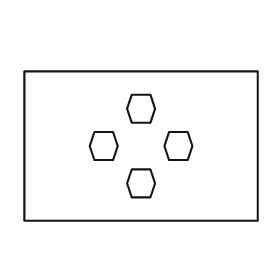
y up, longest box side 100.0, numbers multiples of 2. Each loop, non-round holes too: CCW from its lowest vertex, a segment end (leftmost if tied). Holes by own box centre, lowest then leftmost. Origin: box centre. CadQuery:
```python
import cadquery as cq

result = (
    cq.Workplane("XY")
    .moveTo(-50.0, -32.0)
    .lineTo(50.0, -32.0)
    .lineTo(50.0, 32.0)
    .lineTo(-50.0, 32.0)
    .close()
    .moveTo(-4.0, -22.0)
    .lineTo(4.0, -22.0)
    .lineTo(6.0, -16.0)
    .lineTo(4.0, -10.0)
    .lineTo(-4.0, -10.0)
    .lineTo(-6.0, -16.0)
    .close()
    .moveTo(-20.0, -6.0)
    .lineTo(-12.0, -6.0)
    .lineTo(-10.0, 0.0)
    .lineTo(-12.0, 6.0)
    .lineTo(-20.0, 6.0)
    .lineTo(-22.0, 0.0)
    .close()
    .moveTo(12.0, -6.0)
    .lineTo(20.0, -6.0)
    .lineTo(22.0, 0.0)
    .lineTo(20.0, 6.0)
    .lineTo(12.0, 6.0)
    .lineTo(10.0, 0.0)
    .close()
    .moveTo(-4.0, 10.0)
    .lineTo(4.0, 10.0)
    .lineTo(6.0, 16.0)
    .lineTo(4.0, 22.0)
    .lineTo(-4.0, 22.0)
    .lineTo(-6.0, 16.0)
    .close()
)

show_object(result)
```